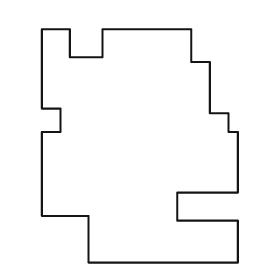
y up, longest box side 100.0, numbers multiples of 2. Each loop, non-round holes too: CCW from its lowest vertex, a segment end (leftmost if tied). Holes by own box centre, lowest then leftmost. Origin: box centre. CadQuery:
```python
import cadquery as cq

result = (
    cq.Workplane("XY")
    .moveTo(-22.0, -50.0)
    .lineTo(42.0, -50.0)
    .lineTo(42.0, -32.0)
    .lineTo(16.0, -32.0)
    .lineTo(16.0, -20.0)
    .lineTo(42.0, -20.0)
    .lineTo(42.0, 6.0)
    .lineTo(38.0, 6.0)
    .lineTo(38.0, 14.0)
    .lineTo(30.0, 14.0)
    .lineTo(30.0, 36.0)
    .lineTo(22.0, 36.0)
    .lineTo(22.0, 50.0)
    .lineTo(-16.0, 50.0)
    .lineTo(-16.0, 38.0)
    .lineTo(-30.0, 38.0)
    .lineTo(-30.0, 50.0)
    .lineTo(-42.0, 50.0)
    .lineTo(-42.0, 16.0)
    .lineTo(-34.0, 16.0)
    .lineTo(-34.0, 6.0)
    .lineTo(-42.0, 6.0)
    .lineTo(-42.0, -30.0)
    .lineTo(-22.0, -30.0)
    .close()
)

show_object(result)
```